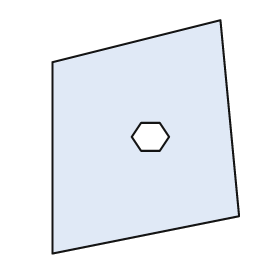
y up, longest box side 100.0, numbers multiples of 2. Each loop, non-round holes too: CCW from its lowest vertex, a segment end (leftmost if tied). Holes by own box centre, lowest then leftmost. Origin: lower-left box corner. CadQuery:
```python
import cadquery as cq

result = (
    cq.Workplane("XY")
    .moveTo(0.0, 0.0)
    .lineTo(80.0, 16.0)
    .lineTo(72.0, 100.0)
    .lineTo(0.0, 82.0)
    .close()
    .moveTo(38.0, 44.0)
    .lineTo(46.0, 44.0)
    .lineTo(50.0, 50.0)
    .lineTo(46.0, 56.0)
    .lineTo(38.0, 56.0)
    .lineTo(34.0, 50.0)
    .close()
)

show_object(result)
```